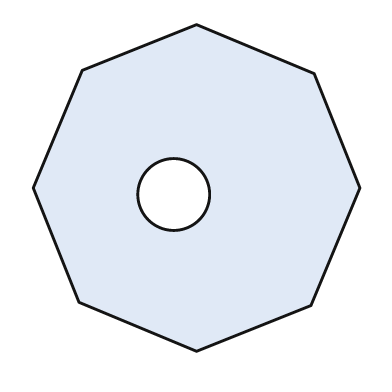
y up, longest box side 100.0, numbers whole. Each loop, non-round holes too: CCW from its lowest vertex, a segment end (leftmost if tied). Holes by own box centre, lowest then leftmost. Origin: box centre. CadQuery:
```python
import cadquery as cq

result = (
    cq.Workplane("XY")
    .moveTo(0.0, -50.0)
    .lineTo(35.0, -36.0)
    .lineTo(50.0, 0.0)
    .lineTo(36.0, 35.0)
    .lineTo(0.0, 50.0)
    .lineTo(-35.0, 36.0)
    .lineTo(-50.0, 0.0)
    .lineTo(-36.0, -35.0)
    .close()
    .moveTo(-7.0, -2.0)
    .circle(11.0)
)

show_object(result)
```